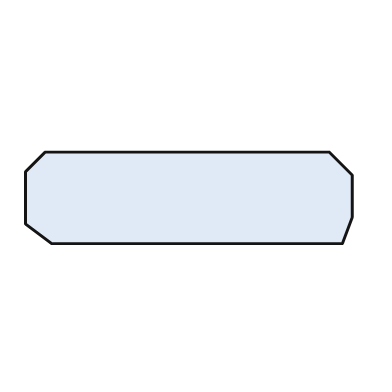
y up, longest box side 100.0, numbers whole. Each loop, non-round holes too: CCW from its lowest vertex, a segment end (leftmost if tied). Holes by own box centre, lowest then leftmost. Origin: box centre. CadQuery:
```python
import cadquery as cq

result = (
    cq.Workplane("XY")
    .moveTo(-42.0, -14.0)
    .lineTo(47.0, -14.0)
    .lineTo(50.0, -6.0)
    .lineTo(50.0, 7.0)
    .lineTo(43.0, 14.0)
    .lineTo(-44.0, 14.0)
    .lineTo(-50.0, 8.0)
    .lineTo(-50.0, -8.0)
    .close()
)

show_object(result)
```